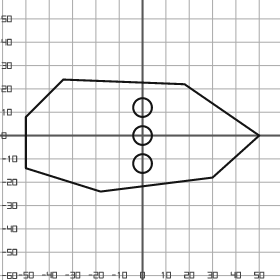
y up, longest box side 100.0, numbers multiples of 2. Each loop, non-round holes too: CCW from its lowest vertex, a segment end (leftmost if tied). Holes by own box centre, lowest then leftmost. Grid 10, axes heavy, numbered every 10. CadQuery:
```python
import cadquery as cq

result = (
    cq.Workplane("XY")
    .moveTo(-18.0, -24.0)
    .lineTo(30.0, -18.0)
    .lineTo(50.0, 0.0)
    .lineTo(18.0, 22.0)
    .lineTo(-34.0, 24.0)
    .lineTo(-50.0, 8.0)
    .lineTo(-50.0, -14.0)
    .close()
    .moveTo(0.0, -12.0)
    .circle(4.0)
    .moveTo(0.0, 0.0)
    .circle(4.0)
    .moveTo(0.0, 12.0)
    .circle(4.0)
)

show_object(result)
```